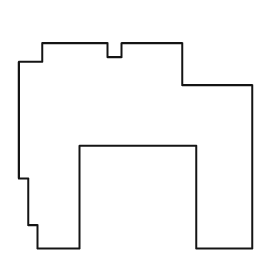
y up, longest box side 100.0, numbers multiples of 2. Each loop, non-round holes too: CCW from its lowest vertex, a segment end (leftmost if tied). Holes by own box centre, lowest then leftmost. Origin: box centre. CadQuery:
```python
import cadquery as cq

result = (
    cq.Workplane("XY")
    .moveTo(-42.0, -44.0)
    .lineTo(-24.0, -44.0)
    .lineTo(-24.0, 0.0)
    .lineTo(26.0, 0.0)
    .lineTo(26.0, -44.0)
    .lineTo(50.0, -44.0)
    .lineTo(50.0, 26.0)
    .lineTo(20.0, 26.0)
    .lineTo(20.0, 44.0)
    .lineTo(-6.0, 44.0)
    .lineTo(-6.0, 38.0)
    .lineTo(-12.0, 38.0)
    .lineTo(-12.0, 44.0)
    .lineTo(-40.0, 44.0)
    .lineTo(-40.0, 36.0)
    .lineTo(-50.0, 36.0)
    .lineTo(-50.0, -14.0)
    .lineTo(-46.0, -14.0)
    .lineTo(-46.0, -34.0)
    .lineTo(-42.0, -34.0)
    .close()
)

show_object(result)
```